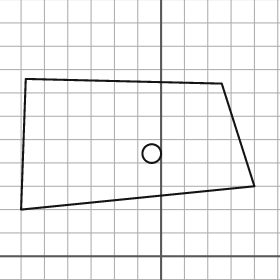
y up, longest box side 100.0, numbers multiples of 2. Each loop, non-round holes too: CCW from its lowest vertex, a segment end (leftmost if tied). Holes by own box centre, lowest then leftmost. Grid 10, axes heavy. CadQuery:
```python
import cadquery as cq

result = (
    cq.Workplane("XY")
    .moveTo(-60.0, 20.0)
    .lineTo(40.0, 30.0)
    .lineTo(26.0, 74.0)
    .lineTo(-58.0, 76.0)
    .close()
    .moveTo(-4.0, 44.0)
    .circle(4.0)
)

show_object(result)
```